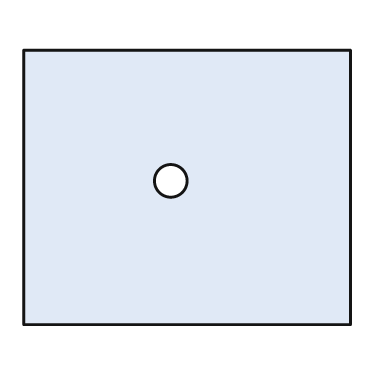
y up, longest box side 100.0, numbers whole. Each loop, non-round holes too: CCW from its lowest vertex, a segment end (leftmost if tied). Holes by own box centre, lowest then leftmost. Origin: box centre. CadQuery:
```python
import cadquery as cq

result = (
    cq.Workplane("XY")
    .moveTo(-50.0, -42.0)
    .lineTo(50.0, -42.0)
    .lineTo(50.0, 42.0)
    .lineTo(-50.0, 42.0)
    .close()
    .moveTo(-5.0, 2.0)
    .circle(5.0)
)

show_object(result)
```